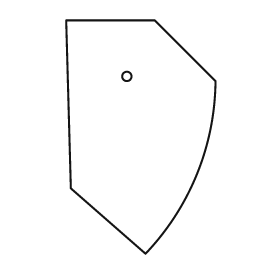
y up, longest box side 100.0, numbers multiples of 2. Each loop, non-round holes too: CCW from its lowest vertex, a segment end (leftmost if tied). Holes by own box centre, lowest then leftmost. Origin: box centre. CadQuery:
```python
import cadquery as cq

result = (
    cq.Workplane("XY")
    .moveTo(2.0, -50.0)
    .threePointArc((24.0, -16.0), (32.0, 24.0))
    .lineTo(6.0, 50.0)
    .lineTo(-32.0, 50.0)
    .lineTo(-30.0, -22.0)
    .close()
    .moveTo(-6.0, 26.0)
    .circle(2.0)
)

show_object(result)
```